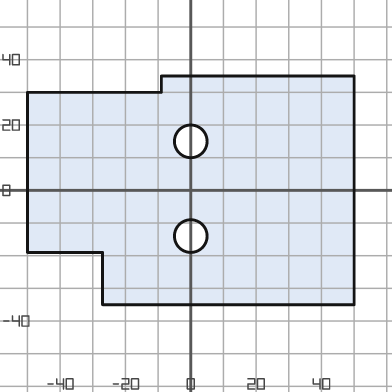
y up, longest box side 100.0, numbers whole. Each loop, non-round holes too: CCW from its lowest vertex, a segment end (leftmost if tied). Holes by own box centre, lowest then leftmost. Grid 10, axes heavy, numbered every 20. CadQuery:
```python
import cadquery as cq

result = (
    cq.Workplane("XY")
    .moveTo(-27.0, -35.0)
    .lineTo(50.0, -35.0)
    .lineTo(50.0, 35.0)
    .lineTo(-9.0, 35.0)
    .lineTo(-9.0, 30.0)
    .lineTo(-50.0, 30.0)
    .lineTo(-50.0, -19.0)
    .lineTo(-27.0, -19.0)
    .close()
    .moveTo(0.0, -14.0)
    .circle(5.0)
    .moveTo(0.0, 15.0)
    .circle(5.0)
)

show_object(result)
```